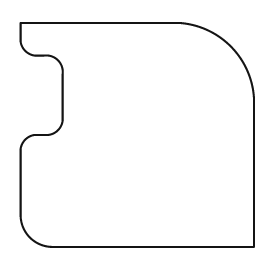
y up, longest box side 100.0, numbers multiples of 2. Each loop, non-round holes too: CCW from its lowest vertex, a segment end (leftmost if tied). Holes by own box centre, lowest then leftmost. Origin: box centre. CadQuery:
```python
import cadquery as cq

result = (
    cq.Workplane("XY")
    .moveTo(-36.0, -48.0)
    .lineTo(50.0, -48.0)
    .lineTo(50.0, 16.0)
    .threePointArc((40.0, 38.0), (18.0, 48.0))
    .lineTo(-50.0, 48.0)
    .lineTo(-50.0, 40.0)
    .threePointArc((-48.0, 36.0), (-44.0, 34.0))
    .lineTo(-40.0, 34.0)
    .threePointArc((-34.0, 32.0), (-32.0, 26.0))
    .lineTo(-32.0, 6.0)
    .threePointArc((-34.0, 2.0), (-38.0, 0.0))
    .lineTo(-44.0, 0.0)
    .threePointArc((-48.0, -2.0), (-50.0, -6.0))
    .lineTo(-50.0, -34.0)
    .threePointArc((-46.0, -44.0), (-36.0, -48.0))
    .close()
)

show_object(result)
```